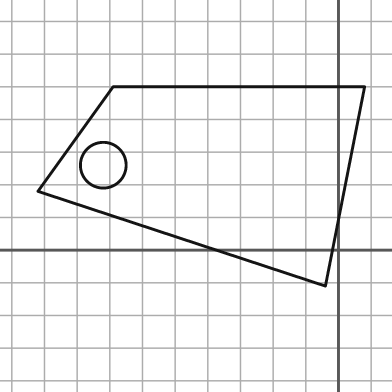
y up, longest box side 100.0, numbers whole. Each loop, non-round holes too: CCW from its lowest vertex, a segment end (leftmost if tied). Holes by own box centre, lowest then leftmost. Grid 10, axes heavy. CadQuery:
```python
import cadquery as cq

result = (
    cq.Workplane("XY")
    .moveTo(-4.0, -11.0)
    .lineTo(8.0, 50.0)
    .lineTo(-69.0, 50.0)
    .lineTo(-92.0, 18.0)
    .close()
    .moveTo(-72.0, 26.0)
    .circle(7.0)
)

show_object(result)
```